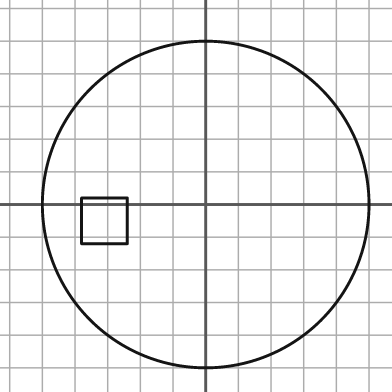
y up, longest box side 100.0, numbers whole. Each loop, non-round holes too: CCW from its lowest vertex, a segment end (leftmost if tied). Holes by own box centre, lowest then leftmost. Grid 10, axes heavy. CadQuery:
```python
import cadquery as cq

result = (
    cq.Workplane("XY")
    .moveTo(0.0, 0.0)
    .circle(50.0)
    .moveTo(-38.0, -12.0)
    .lineTo(-24.0, -12.0)
    .lineTo(-24.0, 2.0)
    .lineTo(-38.0, 2.0)
    .close()
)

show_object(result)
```